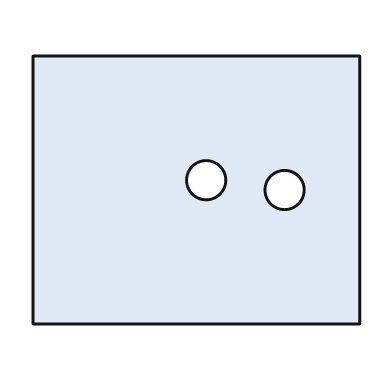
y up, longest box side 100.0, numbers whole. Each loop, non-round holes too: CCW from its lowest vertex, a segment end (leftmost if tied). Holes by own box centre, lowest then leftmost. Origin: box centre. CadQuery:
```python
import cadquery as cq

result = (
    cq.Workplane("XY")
    .moveTo(-50.0, -41.0)
    .lineTo(50.0, -41.0)
    .lineTo(50.0, 41.0)
    .lineTo(-50.0, 41.0)
    .close()
    .moveTo(27.0, 0.0)
    .circle(6.0)
    .moveTo(3.0, 3.0)
    .circle(6.0)
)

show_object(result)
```